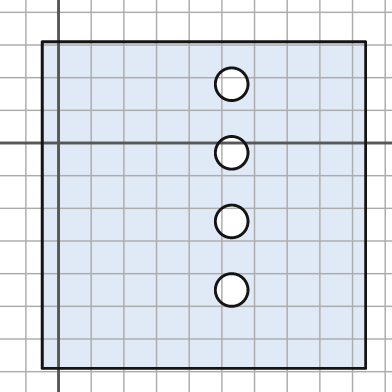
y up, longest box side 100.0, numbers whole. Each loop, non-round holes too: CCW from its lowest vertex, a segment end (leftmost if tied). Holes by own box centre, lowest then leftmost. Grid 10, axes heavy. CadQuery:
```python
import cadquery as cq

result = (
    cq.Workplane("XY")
    .moveTo(-5.0, -69.0)
    .lineTo(94.0, -69.0)
    .lineTo(94.0, 31.0)
    .lineTo(-5.0, 31.0)
    .close()
    .moveTo(53.0, -45.0)
    .circle(5.0)
    .moveTo(53.0, -24.0)
    .circle(5.0)
    .moveTo(53.0, -3.0)
    .circle(5.0)
    .moveTo(53.0, 18.0)
    .circle(5.0)
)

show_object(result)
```